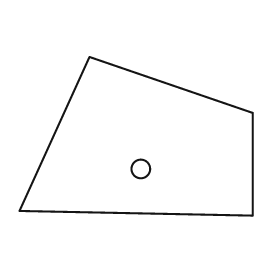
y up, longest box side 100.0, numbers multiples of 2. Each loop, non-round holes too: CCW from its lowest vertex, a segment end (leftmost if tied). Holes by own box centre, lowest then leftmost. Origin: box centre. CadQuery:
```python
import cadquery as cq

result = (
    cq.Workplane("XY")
    .moveTo(50.0, -34.0)
    .lineTo(50.0, 10.0)
    .lineTo(-20.0, 34.0)
    .lineTo(-50.0, -32.0)
    .close()
    .moveTo(2.0, -14.0)
    .circle(4.0)
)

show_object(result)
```